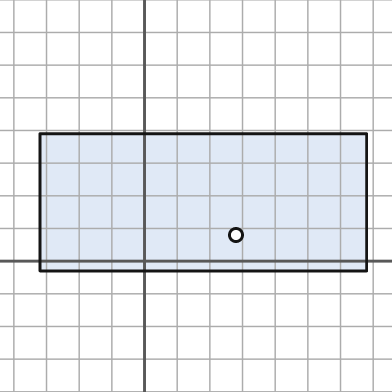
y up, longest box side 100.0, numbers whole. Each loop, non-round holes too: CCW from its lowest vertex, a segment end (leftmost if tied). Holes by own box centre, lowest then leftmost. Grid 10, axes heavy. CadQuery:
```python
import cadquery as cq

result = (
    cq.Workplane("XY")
    .moveTo(-32.0, -3.0)
    .lineTo(68.0, -3.0)
    .lineTo(68.0, 39.0)
    .lineTo(-32.0, 39.0)
    .close()
    .moveTo(28.0, 8.0)
    .circle(2.0)
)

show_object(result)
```